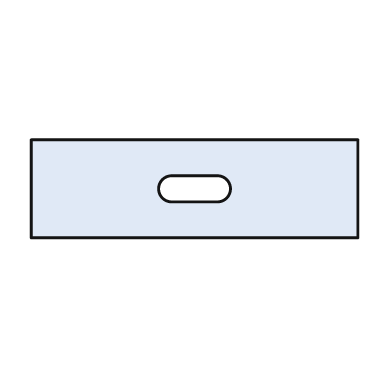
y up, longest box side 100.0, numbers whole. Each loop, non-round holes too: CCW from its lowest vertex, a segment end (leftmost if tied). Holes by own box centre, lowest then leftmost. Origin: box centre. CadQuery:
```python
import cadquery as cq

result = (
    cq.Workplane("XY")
    .moveTo(-50.0, -15.0)
    .lineTo(50.0, -15.0)
    .lineTo(50.0, 15.0)
    .lineTo(-50.0, 15.0)
    .close()
    .moveTo(-7.0, -4.0)
    .lineTo(7.0, -4.0)
    .threePointArc((11.0, 0.0), (7.0, 4.0))
    .lineTo(-7.0, 4.0)
    .threePointArc((-11.0, 0.0), (-7.0, -4.0))
    .close()
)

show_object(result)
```